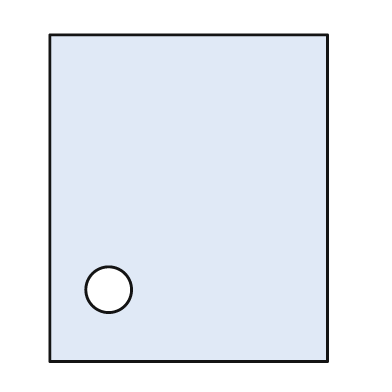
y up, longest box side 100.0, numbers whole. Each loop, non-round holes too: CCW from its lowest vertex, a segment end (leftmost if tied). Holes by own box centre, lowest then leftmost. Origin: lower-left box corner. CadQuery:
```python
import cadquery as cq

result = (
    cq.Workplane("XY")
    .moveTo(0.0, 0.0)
    .lineTo(85.0, 0.0)
    .lineTo(85.0, 100.0)
    .lineTo(0.0, 100.0)
    .close()
    .moveTo(18.0, 22.0)
    .circle(7.0)
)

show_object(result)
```